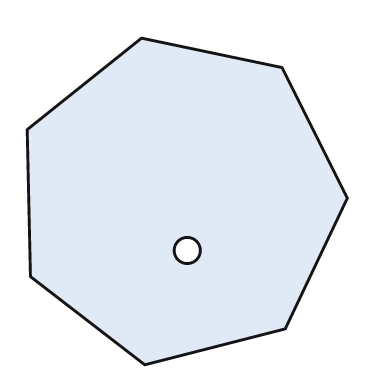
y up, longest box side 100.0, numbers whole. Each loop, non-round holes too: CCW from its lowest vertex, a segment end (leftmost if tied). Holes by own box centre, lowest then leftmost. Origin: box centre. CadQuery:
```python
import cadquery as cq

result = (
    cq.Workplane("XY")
    .moveTo(-13.0, -50.0)
    .lineTo(30.0, -39.0)
    .lineTo(49.0, 1.0)
    .lineTo(29.0, 41.0)
    .lineTo(-14.0, 50.0)
    .lineTo(-49.0, 22.0)
    .lineTo(-48.0, -23.0)
    .close()
    .moveTo(0.0, -15.0)
    .circle(4.0)
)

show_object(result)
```